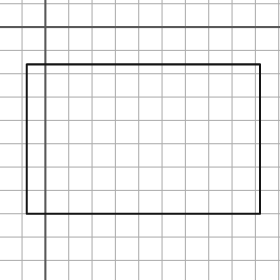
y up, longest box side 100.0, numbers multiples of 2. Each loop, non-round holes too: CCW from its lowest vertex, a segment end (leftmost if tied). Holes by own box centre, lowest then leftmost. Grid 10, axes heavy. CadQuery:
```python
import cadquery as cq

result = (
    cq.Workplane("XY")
    .moveTo(-8.0, -80.0)
    .lineTo(92.0, -80.0)
    .lineTo(92.0, -16.0)
    .lineTo(-8.0, -16.0)
    .close()
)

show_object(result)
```